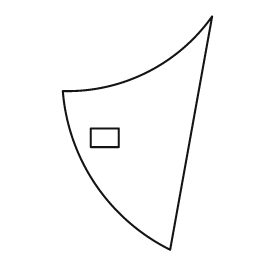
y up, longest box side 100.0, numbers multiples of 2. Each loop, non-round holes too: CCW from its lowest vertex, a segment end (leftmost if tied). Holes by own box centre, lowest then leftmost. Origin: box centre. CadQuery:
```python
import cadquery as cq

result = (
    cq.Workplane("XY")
    .moveTo(14.0, -50.0)
    .lineTo(32.0, 50.0)
    .threePointArc((4.0, 26.0), (-32.0, 18.0))
    .threePointArc((-18.0, -22.0), (14.0, -50.0))
    .close()
    .moveTo(-20.0, -6.0)
    .lineTo(-8.0, -6.0)
    .lineTo(-8.0, 2.0)
    .lineTo(-20.0, 2.0)
    .close()
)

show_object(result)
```